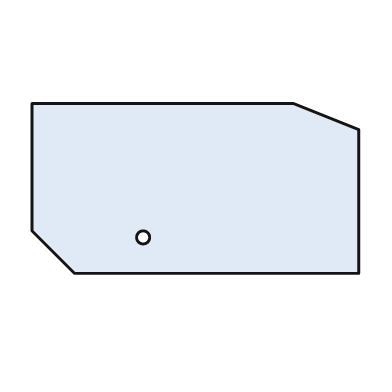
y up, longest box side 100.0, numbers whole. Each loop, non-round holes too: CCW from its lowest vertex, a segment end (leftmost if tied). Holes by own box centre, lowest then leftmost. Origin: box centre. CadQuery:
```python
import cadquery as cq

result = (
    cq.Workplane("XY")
    .moveTo(-37.0, -26.0)
    .lineTo(50.0, -26.0)
    .lineTo(50.0, 18.0)
    .lineTo(30.0, 26.0)
    .lineTo(-50.0, 26.0)
    .lineTo(-50.0, -13.0)
    .close()
    .moveTo(-16.0, -15.0)
    .circle(2.0)
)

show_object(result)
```